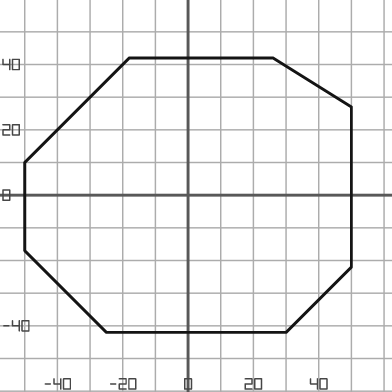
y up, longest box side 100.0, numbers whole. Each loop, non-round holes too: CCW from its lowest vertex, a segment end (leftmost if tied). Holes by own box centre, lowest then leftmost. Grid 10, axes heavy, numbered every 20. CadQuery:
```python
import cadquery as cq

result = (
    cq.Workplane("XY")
    .moveTo(-25.0, -42.0)
    .lineTo(30.0, -42.0)
    .lineTo(50.0, -22.0)
    .lineTo(50.0, 27.0)
    .lineTo(26.0, 42.0)
    .lineTo(-18.0, 42.0)
    .lineTo(-50.0, 10.0)
    .lineTo(-50.0, -17.0)
    .close()
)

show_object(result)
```